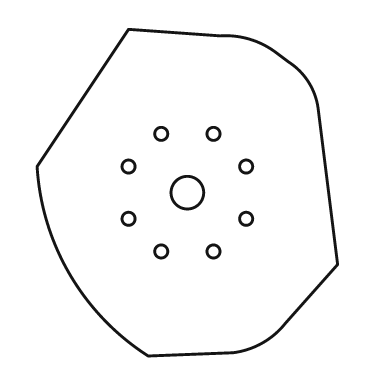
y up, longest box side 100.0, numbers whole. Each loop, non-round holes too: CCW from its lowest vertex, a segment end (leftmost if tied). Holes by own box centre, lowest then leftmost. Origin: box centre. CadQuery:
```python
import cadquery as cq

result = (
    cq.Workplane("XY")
    .moveTo(-12.0, -50.0)
    .lineTo(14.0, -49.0)
    .threePointArc((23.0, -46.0), (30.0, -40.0))
    .lineTo(46.0, -22.0)
    .lineTo(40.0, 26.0)
    .threePointArc((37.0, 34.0), (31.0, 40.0))
    .lineTo(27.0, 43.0)
    .threePointArc((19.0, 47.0), (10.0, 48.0))
    .lineTo(-18.0, 50.0)
    .lineTo(-46.0, 8.0)
    .threePointArc((-36.0, -25.0), (-12.0, -50.0))
    .close()
    .moveTo(-8.0, -18.0)
    .circle(2.0)
    .moveTo(8.0, -18.0)
    .circle(2.0)
    .moveTo(-18.0, -8.0)
    .circle(2.0)
    .moveTo(18.0, -8.0)
    .circle(2.0)
    .moveTo(0.0, 0.0)
    .circle(5.0)
    .moveTo(-18.0, 8.0)
    .circle(2.0)
    .moveTo(18.0, 8.0)
    .circle(2.0)
    .moveTo(-8.0, 18.0)
    .circle(2.0)
    .moveTo(8.0, 18.0)
    .circle(2.0)
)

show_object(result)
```